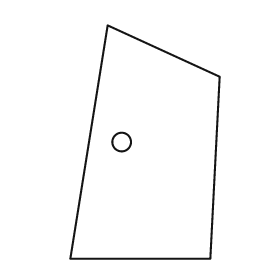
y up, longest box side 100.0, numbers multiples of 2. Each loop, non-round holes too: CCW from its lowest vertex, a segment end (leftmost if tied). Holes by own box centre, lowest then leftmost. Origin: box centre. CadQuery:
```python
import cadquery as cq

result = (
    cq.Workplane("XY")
    .moveTo(-32.0, -50.0)
    .lineTo(28.0, -50.0)
    .lineTo(32.0, 28.0)
    .lineTo(-16.0, 50.0)
    .close()
    .moveTo(-10.0, 0.0)
    .circle(4.0)
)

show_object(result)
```